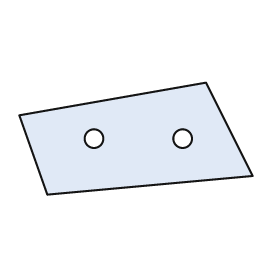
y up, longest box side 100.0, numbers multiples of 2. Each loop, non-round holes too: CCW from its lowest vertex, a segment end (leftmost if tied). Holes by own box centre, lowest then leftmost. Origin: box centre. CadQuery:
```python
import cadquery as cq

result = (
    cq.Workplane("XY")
    .moveTo(-38.0, -24.0)
    .lineTo(50.0, -16.0)
    .lineTo(30.0, 24.0)
    .lineTo(-50.0, 10.0)
    .close()
    .moveTo(-18.0, 0.0)
    .circle(4.0)
    .moveTo(20.0, 0.0)
    .circle(4.0)
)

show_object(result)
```